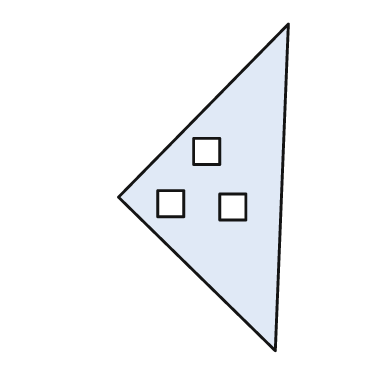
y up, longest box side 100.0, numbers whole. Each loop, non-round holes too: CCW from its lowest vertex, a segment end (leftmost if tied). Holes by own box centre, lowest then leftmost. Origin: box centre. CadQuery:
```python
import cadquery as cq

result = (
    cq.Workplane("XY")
    .moveTo(22.0, -50.0)
    .lineTo(26.0, 50.0)
    .lineTo(-26.0, -3.0)
    .close()
    .moveTo(5.0, -10.0)
    .lineTo(13.0, -10.0)
    .lineTo(13.0, -2.0)
    .lineTo(5.0, -2.0)
    .close()
    .moveTo(-14.0, -9.0)
    .lineTo(-6.0, -9.0)
    .lineTo(-6.0, -1.0)
    .lineTo(-14.0, -1.0)
    .close()
    .moveTo(-3.0, 7.0)
    .lineTo(5.0, 7.0)
    .lineTo(5.0, 15.0)
    .lineTo(-3.0, 15.0)
    .close()
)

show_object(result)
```